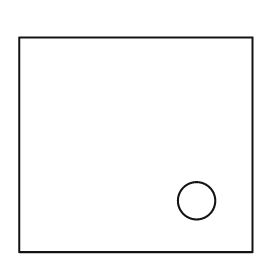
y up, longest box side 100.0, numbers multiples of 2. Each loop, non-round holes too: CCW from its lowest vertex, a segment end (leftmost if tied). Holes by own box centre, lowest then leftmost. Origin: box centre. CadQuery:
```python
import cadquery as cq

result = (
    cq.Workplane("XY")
    .moveTo(-50.0, -46.0)
    .lineTo(50.0, -46.0)
    .lineTo(50.0, 46.0)
    .lineTo(-50.0, 46.0)
    .close()
    .moveTo(26.0, -24.0)
    .circle(8.0)
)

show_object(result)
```